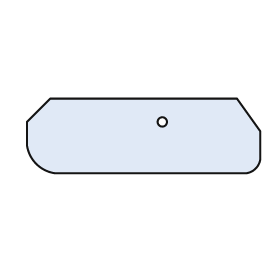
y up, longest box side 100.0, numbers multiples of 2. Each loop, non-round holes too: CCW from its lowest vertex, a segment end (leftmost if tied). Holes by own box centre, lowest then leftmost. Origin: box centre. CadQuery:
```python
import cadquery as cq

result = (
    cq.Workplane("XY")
    .moveTo(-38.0, -16.0)
    .lineTo(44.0, -16.0)
    .threePointArc((48.0, -14.0), (50.0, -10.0))
    .lineTo(50.0, 2.0)
    .lineTo(40.0, 16.0)
    .lineTo(-40.0, 16.0)
    .lineTo(-50.0, 6.0)
    .lineTo(-50.0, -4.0)
    .threePointArc((-46.0, -12.0), (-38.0, -16.0))
    .close()
    .moveTo(8.0, 6.0)
    .circle(2.0)
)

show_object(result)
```